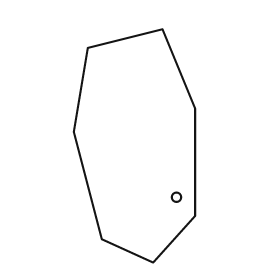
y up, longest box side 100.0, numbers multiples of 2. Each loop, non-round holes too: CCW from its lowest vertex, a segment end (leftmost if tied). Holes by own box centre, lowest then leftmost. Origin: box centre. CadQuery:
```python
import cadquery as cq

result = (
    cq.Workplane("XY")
    .moveTo(8.0, -50.0)
    .lineTo(26.0, -30.0)
    .lineTo(26.0, 16.0)
    .lineTo(12.0, 50.0)
    .lineTo(-20.0, 42.0)
    .lineTo(-26.0, 6.0)
    .lineTo(-14.0, -40.0)
    .close()
    .moveTo(18.0, -22.0)
    .circle(2.0)
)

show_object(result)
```